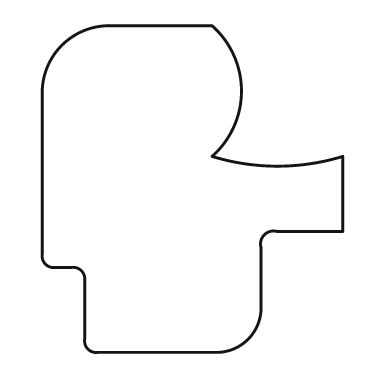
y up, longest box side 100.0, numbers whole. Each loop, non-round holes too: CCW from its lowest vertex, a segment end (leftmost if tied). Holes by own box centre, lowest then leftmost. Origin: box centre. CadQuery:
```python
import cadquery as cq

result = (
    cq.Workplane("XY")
    .moveTo(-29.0, -50.0)
    .lineTo(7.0, -50.0)
    .threePointArc((17.0, -46.0), (21.0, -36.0))
    .lineTo(21.0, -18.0)
    .threePointArc((22.0, -14.0), (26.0, -13.0))
    .lineTo(46.0, -13.0)
    .lineTo(46.0, 10.0)
    .threePointArc((26.0, 7.0), (6.0, 10.0))
    .threePointArc((15.0, 30.0), (6.0, 50.0))
    .lineTo(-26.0, 50.0)
    .threePointArc((-40.0, 44.0), (-46.0, 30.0))
    .lineTo(-46.0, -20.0)
    .threePointArc((-45.0, -23.0), (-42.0, -24.0))
    .lineTo(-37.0, -24.0)
    .threePointArc((-34.0, -25.0), (-33.0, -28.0))
    .lineTo(-33.0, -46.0)
    .threePointArc((-32.0, -49.0), (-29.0, -50.0))
    .close()
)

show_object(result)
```